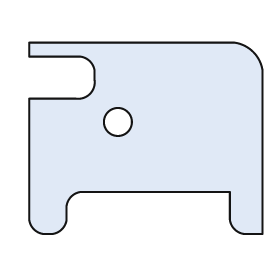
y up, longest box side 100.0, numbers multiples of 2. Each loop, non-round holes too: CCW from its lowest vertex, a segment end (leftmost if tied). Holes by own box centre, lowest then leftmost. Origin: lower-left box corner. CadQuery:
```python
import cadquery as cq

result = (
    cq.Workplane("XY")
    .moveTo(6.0, 0.0)
    .lineTo(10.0, 0.0)
    .threePointArc((14.0, 2.0), (16.0, 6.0))
    .lineTo(16.0, 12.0)
    .threePointArc((18.0, 16.0), (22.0, 18.0))
    .lineTo(86.0, 18.0)
    .lineTo(86.0, 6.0)
    .threePointArc((88.0, 2.0), (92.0, 0.0))
    .lineTo(100.0, 0.0)
    .lineTo(100.0, 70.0)
    .threePointArc((96.0, 78.0), (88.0, 82.0))
    .lineTo(0.0, 82.0)
    .lineTo(0.0, 76.0)
    .lineTo(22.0, 76.0)
    .threePointArc((26.0, 74.0), (28.0, 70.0))
    .lineTo(28.0, 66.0)
    .threePointArc((26.0, 60.0), (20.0, 58.0))
    .lineTo(0.0, 58.0)
    .lineTo(0.0, 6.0)
    .threePointArc((2.0, 2.0), (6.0, 0.0))
    .close()
    .moveTo(38.0, 48.0)
    .circle(6.0)
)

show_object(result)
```